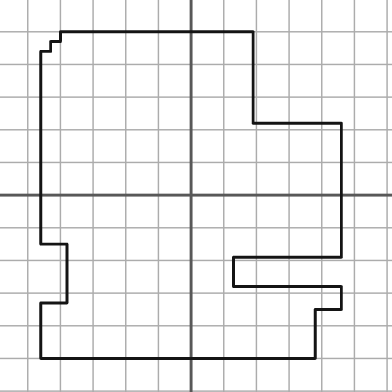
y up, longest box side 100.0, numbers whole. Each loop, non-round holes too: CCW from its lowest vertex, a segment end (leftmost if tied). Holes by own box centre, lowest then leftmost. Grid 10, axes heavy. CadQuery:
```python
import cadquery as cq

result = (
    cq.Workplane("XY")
    .moveTo(-46.0, -50.0)
    .lineTo(38.0, -50.0)
    .lineTo(38.0, -35.0)
    .lineTo(46.0, -35.0)
    .lineTo(46.0, -28.0)
    .lineTo(13.0, -28.0)
    .lineTo(13.0, -19.0)
    .lineTo(46.0, -19.0)
    .lineTo(46.0, 22.0)
    .lineTo(19.0, 22.0)
    .lineTo(19.0, 50.0)
    .lineTo(-40.0, 50.0)
    .lineTo(-40.0, 47.0)
    .lineTo(-43.0, 47.0)
    .lineTo(-43.0, 44.0)
    .lineTo(-46.0, 44.0)
    .lineTo(-46.0, -15.0)
    .lineTo(-38.0, -15.0)
    .lineTo(-38.0, -33.0)
    .lineTo(-46.0, -33.0)
    .close()
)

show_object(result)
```